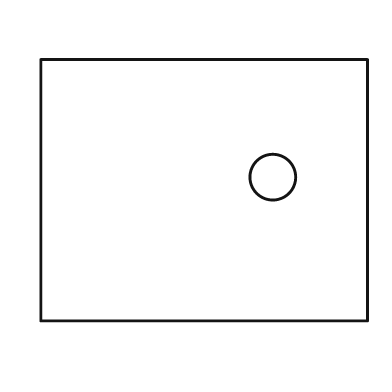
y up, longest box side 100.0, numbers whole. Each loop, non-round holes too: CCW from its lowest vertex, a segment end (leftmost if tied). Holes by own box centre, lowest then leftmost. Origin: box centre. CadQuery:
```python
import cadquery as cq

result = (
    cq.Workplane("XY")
    .moveTo(-50.0, -40.0)
    .lineTo(50.0, -40.0)
    .lineTo(50.0, 40.0)
    .lineTo(-50.0, 40.0)
    .close()
    .moveTo(21.0, 4.0)
    .circle(7.0)
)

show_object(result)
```